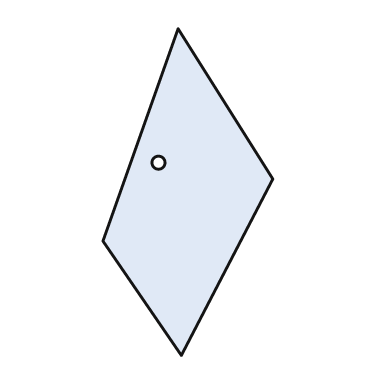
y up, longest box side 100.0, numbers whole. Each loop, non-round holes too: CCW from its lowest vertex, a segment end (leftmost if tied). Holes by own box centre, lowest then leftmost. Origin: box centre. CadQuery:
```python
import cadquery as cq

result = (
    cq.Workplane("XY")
    .moveTo(-2.0, -50.0)
    .lineTo(26.0, 4.0)
    .lineTo(-3.0, 50.0)
    .lineTo(-26.0, -15.0)
    .close()
    .moveTo(-9.0, 9.0)
    .circle(2.0)
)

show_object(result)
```